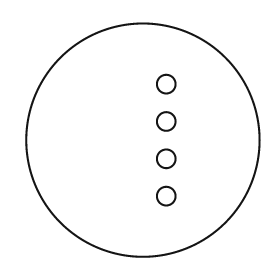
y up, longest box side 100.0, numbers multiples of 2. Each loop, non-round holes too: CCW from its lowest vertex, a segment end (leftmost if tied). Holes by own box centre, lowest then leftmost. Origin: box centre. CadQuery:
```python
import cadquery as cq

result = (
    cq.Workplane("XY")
    .moveTo(0.0, 0.0)
    .circle(50.0)
    .moveTo(10.0, -24.0)
    .circle(4.0)
    .moveTo(10.0, -8.0)
    .circle(4.0)
    .moveTo(10.0, 8.0)
    .circle(4.0)
    .moveTo(10.0, 24.0)
    .circle(4.0)
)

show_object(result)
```